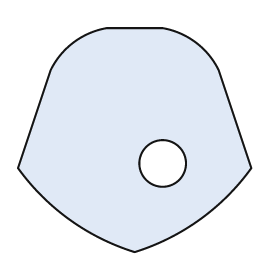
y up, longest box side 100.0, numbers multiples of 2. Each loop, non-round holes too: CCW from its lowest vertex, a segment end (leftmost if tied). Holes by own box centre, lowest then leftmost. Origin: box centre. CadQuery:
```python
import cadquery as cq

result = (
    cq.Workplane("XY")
    .moveTo(0.0, -48.0)
    .threePointArc((28.0, -34.0), (50.0, -12.0))
    .lineTo(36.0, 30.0)
    .threePointArc((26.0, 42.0), (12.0, 48.0))
    .lineTo(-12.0, 48.0)
    .threePointArc((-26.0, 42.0), (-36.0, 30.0))
    .lineTo(-50.0, -12.0)
    .threePointArc((-28.0, -34.0), (0.0, -48.0))
    .close()
    .moveTo(12.0, -10.0)
    .circle(10.0)
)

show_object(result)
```